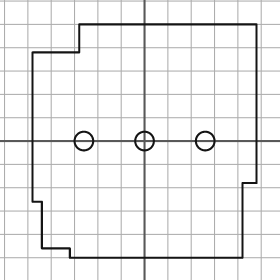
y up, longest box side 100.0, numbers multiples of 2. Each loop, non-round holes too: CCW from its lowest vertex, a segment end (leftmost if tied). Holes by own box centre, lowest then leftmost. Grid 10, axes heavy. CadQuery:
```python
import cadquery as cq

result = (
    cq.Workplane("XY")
    .moveTo(-32.0, -50.0)
    .lineTo(42.0, -50.0)
    .lineTo(42.0, -18.0)
    .lineTo(48.0, -18.0)
    .lineTo(48.0, 50.0)
    .lineTo(-28.0, 50.0)
    .lineTo(-28.0, 38.0)
    .lineTo(-48.0, 38.0)
    .lineTo(-48.0, -26.0)
    .lineTo(-44.0, -26.0)
    .lineTo(-44.0, -46.0)
    .lineTo(-32.0, -46.0)
    .close()
    .moveTo(-26.0, 0.0)
    .circle(4.0)
    .moveTo(0.0, 0.0)
    .circle(4.0)
    .moveTo(26.0, 0.0)
    .circle(4.0)
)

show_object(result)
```